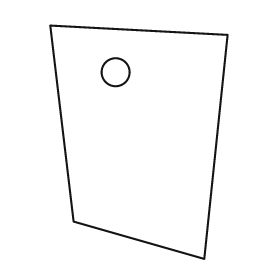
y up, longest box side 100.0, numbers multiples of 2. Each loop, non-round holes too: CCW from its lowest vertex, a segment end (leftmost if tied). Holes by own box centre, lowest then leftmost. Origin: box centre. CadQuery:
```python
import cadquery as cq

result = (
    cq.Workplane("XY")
    .moveTo(28.0, -50.0)
    .lineTo(38.0, 46.0)
    .lineTo(-38.0, 50.0)
    .lineTo(-28.0, -34.0)
    .close()
    .moveTo(-10.0, 30.0)
    .circle(6.0)
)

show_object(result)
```